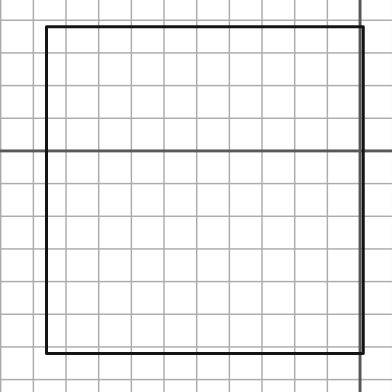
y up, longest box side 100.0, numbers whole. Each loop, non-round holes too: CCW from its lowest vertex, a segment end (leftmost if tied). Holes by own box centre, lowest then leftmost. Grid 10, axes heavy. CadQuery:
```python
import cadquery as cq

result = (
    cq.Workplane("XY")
    .moveTo(-96.0, -62.0)
    .lineTo(1.0, -62.0)
    .lineTo(1.0, 38.0)
    .lineTo(-96.0, 38.0)
    .close()
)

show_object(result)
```